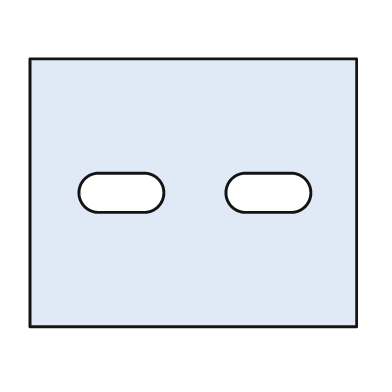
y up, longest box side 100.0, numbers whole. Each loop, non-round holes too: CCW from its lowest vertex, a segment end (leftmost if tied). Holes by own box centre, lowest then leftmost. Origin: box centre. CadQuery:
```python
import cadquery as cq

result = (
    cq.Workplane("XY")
    .moveTo(-50.0, -41.0)
    .lineTo(50.0, -41.0)
    .lineTo(50.0, 41.0)
    .lineTo(-50.0, 41.0)
    .close()
    .moveTo(-29.0, -6.0)
    .lineTo(-15.0, -6.0)
    .threePointArc((-9.0, 0.0), (-15.0, 6.0))
    .lineTo(-29.0, 6.0)
    .threePointArc((-35.0, 0.0), (-29.0, -6.0))
    .close()
    .moveTo(16.0, -6.0)
    .lineTo(30.0, -6.0)
    .threePointArc((36.0, 0.0), (30.0, 6.0))
    .lineTo(16.0, 6.0)
    .threePointArc((10.0, 0.0), (16.0, -6.0))
    .close()
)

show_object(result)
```